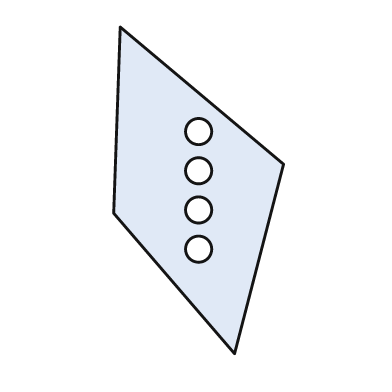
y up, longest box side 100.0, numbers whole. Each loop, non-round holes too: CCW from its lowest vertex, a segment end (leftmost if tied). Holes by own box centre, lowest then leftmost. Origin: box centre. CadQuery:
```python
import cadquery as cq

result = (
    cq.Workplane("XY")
    .moveTo(11.0, -50.0)
    .lineTo(26.0, 8.0)
    .lineTo(-24.0, 50.0)
    .lineTo(-26.0, -7.0)
    .close()
    .moveTo(0.0, -18.0)
    .circle(4.0)
    .moveTo(0.0, -6.0)
    .circle(4.0)
    .moveTo(0.0, 6.0)
    .circle(4.0)
    .moveTo(0.0, 18.0)
    .circle(4.0)
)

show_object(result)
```